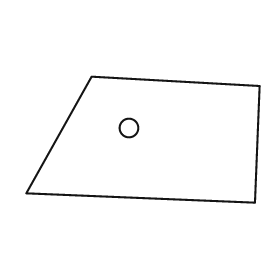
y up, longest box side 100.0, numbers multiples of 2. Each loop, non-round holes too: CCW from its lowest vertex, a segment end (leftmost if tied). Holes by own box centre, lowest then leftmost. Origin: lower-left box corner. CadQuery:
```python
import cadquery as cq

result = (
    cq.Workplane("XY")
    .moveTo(98.0, 0.0)
    .lineTo(100.0, 50.0)
    .lineTo(28.0, 54.0)
    .lineTo(0.0, 4.0)
    .close()
    .moveTo(44.0, 32.0)
    .circle(4.0)
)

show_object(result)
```